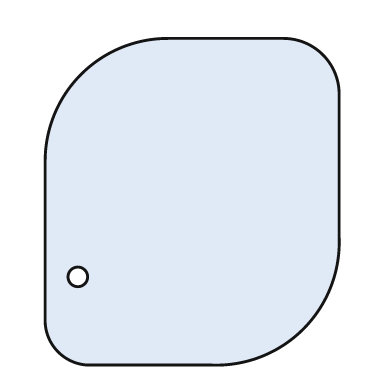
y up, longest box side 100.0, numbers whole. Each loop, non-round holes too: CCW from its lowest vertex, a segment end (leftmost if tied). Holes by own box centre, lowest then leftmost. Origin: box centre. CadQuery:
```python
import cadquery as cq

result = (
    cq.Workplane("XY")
    .moveTo(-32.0, -50.0)
    .lineTo(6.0, -50.0)
    .threePointArc((34.0, -39.0), (45.0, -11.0))
    .lineTo(45.0, 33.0)
    .threePointArc((40.0, 45.0), (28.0, 50.0))
    .lineTo(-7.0, 50.0)
    .threePointArc((-34.0, 39.0), (-45.0, 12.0))
    .lineTo(-45.0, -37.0)
    .threePointArc((-41.0, -46.0), (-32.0, -50.0))
    .close()
    .moveTo(-35.0, -23.0)
    .circle(3.0)
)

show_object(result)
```